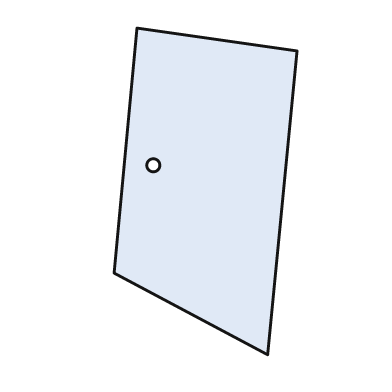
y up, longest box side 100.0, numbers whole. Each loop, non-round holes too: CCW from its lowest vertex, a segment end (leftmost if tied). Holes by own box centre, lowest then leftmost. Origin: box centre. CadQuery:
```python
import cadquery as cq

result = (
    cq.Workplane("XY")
    .moveTo(19.0, -50.0)
    .lineTo(28.0, 43.0)
    .lineTo(-21.0, 50.0)
    .lineTo(-28.0, -25.0)
    .close()
    .moveTo(-16.0, 8.0)
    .circle(2.0)
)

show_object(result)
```